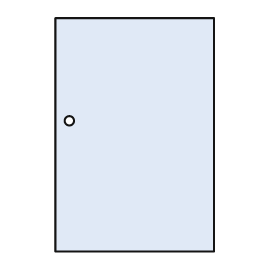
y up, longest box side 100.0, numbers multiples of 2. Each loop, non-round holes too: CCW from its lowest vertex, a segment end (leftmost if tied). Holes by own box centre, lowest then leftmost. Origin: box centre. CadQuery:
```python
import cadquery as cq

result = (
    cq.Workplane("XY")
    .moveTo(-34.0, -50.0)
    .lineTo(34.0, -50.0)
    .lineTo(34.0, 50.0)
    .lineTo(-34.0, 50.0)
    .close()
    .moveTo(-28.0, 6.0)
    .circle(2.0)
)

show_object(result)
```